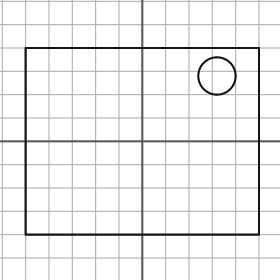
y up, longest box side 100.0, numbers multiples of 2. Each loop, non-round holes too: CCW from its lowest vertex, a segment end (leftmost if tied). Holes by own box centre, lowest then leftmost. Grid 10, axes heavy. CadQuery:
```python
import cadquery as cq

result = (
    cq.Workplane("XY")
    .moveTo(-50.0, -40.0)
    .lineTo(50.0, -40.0)
    .lineTo(50.0, 40.0)
    .lineTo(-50.0, 40.0)
    .close()
    .moveTo(32.0, 28.0)
    .circle(8.0)
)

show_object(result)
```